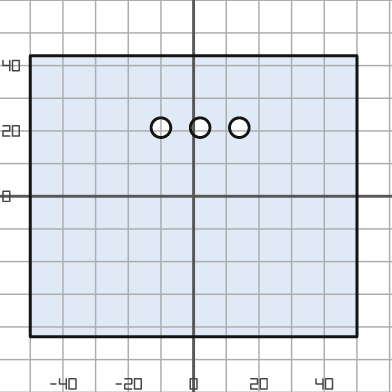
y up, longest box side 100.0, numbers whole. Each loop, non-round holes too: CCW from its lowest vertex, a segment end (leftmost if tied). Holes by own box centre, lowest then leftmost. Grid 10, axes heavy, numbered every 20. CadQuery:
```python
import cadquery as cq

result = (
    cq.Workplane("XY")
    .moveTo(-50.0, -43.0)
    .lineTo(50.0, -43.0)
    .lineTo(50.0, 43.0)
    .lineTo(-50.0, 43.0)
    .close()
    .moveTo(-10.0, 21.0)
    .circle(3.0)
    .moveTo(2.0, 21.0)
    .circle(3.0)
    .moveTo(14.0, 21.0)
    .circle(3.0)
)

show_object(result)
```